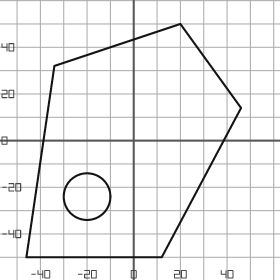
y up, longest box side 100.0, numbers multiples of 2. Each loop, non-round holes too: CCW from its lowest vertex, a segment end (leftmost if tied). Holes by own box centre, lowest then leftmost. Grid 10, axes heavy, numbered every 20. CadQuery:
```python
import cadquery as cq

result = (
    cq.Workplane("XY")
    .moveTo(-46.0, -50.0)
    .lineTo(12.0, -50.0)
    .lineTo(46.0, 14.0)
    .lineTo(20.0, 50.0)
    .lineTo(-34.0, 32.0)
    .close()
    .moveTo(-20.0, -24.0)
    .circle(10.0)
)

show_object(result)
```